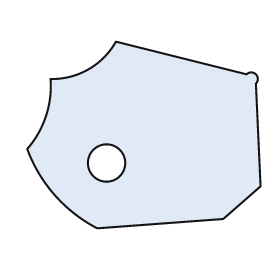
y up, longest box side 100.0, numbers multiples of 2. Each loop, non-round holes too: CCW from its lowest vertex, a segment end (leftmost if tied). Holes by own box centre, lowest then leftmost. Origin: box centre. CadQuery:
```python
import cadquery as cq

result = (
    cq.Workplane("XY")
    .moveTo(-20.0, -40.0)
    .lineTo(34.0, -36.0)
    .lineTo(50.0, -22.0)
    .lineTo(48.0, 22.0)
    .threePointArc((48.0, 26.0), (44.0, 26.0))
    .lineTo(-12.0, 40.0)
    .threePointArc((-24.0, 28.0), (-40.0, 24.0))
    .threePointArc((-42.0, 8.0), (-50.0, -6.0))
    .threePointArc((-38.0, -26.0), (-20.0, -40.0))
    .close()
    .moveTo(-16.0, -12.0)
    .circle(8.0)
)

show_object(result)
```